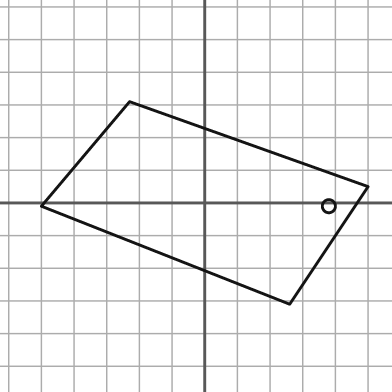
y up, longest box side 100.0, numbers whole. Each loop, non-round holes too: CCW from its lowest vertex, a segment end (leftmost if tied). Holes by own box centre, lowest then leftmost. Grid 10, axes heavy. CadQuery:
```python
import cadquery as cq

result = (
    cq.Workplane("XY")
    .moveTo(26.0, -31.0)
    .lineTo(50.0, 5.0)
    .lineTo(-23.0, 31.0)
    .lineTo(-50.0, -1.0)
    .close()
    .moveTo(38.0, -1.0)
    .circle(2.0)
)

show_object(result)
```